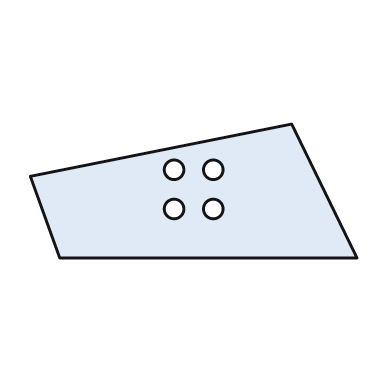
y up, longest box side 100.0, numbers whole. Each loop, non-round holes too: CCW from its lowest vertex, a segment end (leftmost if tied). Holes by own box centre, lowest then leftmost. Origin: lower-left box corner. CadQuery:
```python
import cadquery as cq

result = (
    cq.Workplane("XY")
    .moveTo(9.0, 0.0)
    .lineTo(100.0, 0.0)
    .lineTo(80.0, 41.0)
    .lineTo(0.0, 25.0)
    .close()
    .moveTo(44.0, 15.0)
    .circle(3.0)
    .moveTo(56.0, 15.0)
    .circle(3.0)
    .moveTo(44.0, 27.0)
    .circle(3.0)
    .moveTo(56.0, 27.0)
    .circle(3.0)
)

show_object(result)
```